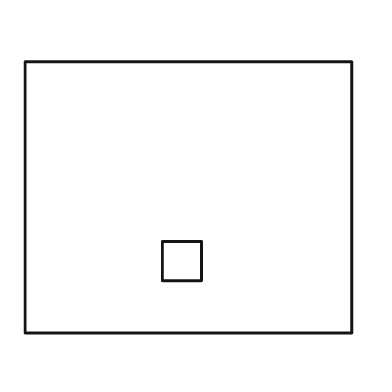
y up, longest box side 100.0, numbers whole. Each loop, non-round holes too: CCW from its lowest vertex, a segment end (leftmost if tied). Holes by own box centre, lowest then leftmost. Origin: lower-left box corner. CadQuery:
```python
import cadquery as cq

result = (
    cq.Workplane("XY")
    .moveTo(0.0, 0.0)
    .lineTo(100.0, 0.0)
    .lineTo(100.0, 83.0)
    .lineTo(0.0, 83.0)
    .close()
    .moveTo(42.0, 16.0)
    .lineTo(54.0, 16.0)
    .lineTo(54.0, 28.0)
    .lineTo(42.0, 28.0)
    .close()
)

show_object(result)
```